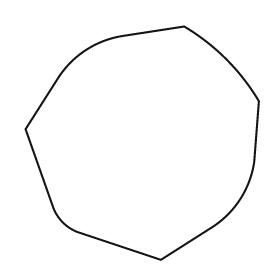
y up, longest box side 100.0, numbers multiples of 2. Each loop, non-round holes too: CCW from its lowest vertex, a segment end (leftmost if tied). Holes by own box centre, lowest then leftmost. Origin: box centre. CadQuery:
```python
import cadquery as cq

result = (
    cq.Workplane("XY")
    .moveTo(8.0, -50.0)
    .lineTo(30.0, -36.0)
    .threePointArc((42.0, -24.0), (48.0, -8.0))
    .lineTo(50.0, 18.0)
    .threePointArc((36.0, 36.0), (18.0, 50.0))
    .lineTo(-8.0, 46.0)
    .threePointArc((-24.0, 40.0), (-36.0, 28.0))
    .lineTo(-50.0, 6.0)
    .lineTo(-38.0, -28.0)
    .threePointArc((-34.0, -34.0), (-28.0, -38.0))
    .close()
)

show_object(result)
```